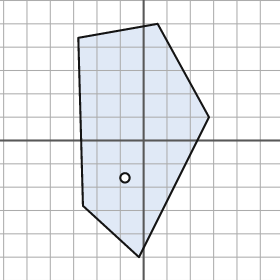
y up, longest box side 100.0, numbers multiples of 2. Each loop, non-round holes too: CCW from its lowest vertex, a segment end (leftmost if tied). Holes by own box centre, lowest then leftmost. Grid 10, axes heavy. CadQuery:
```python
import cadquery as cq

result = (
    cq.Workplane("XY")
    .moveTo(-2.0, -50.0)
    .lineTo(28.0, 10.0)
    .lineTo(6.0, 50.0)
    .lineTo(-28.0, 44.0)
    .lineTo(-26.0, -28.0)
    .close()
    .moveTo(-8.0, -16.0)
    .circle(2.0)
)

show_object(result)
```